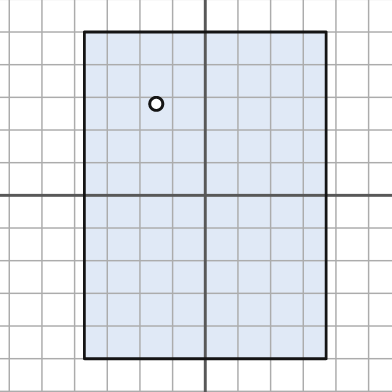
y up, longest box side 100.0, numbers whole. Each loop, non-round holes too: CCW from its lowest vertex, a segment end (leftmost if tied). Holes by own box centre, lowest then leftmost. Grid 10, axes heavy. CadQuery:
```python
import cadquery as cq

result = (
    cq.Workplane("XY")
    .moveTo(-37.0, -50.0)
    .lineTo(37.0, -50.0)
    .lineTo(37.0, 50.0)
    .lineTo(-37.0, 50.0)
    .close()
    .moveTo(-15.0, 28.0)
    .circle(2.0)
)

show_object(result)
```